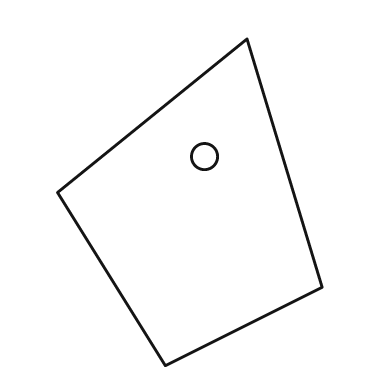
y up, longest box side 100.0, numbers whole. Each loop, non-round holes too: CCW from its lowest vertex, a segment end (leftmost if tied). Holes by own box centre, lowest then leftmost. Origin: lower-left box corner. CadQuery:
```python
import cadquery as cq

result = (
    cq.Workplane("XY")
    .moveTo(33.0, 0.0)
    .lineTo(81.0, 24.0)
    .lineTo(58.0, 100.0)
    .lineTo(0.0, 53.0)
    .close()
    .moveTo(45.0, 64.0)
    .circle(4.0)
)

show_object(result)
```